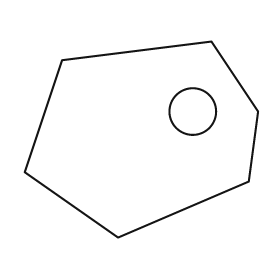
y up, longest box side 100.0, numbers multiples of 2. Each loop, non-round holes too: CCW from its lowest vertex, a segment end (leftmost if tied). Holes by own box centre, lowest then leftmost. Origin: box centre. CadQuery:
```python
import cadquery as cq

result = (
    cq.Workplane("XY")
    .moveTo(-10.0, -42.0)
    .lineTo(46.0, -18.0)
    .lineTo(50.0, 12.0)
    .lineTo(30.0, 42.0)
    .lineTo(-34.0, 34.0)
    .lineTo(-50.0, -14.0)
    .close()
    .moveTo(22.0, 12.0)
    .circle(10.0)
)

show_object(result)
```